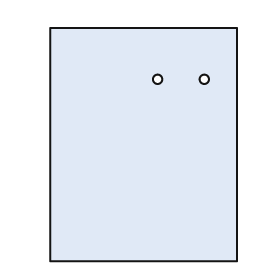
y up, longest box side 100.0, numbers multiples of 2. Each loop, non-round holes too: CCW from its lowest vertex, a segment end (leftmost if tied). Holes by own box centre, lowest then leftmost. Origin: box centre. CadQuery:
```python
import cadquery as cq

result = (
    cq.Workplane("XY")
    .moveTo(-40.0, -50.0)
    .lineTo(40.0, -50.0)
    .lineTo(40.0, 50.0)
    .lineTo(-40.0, 50.0)
    .close()
    .moveTo(6.0, 28.0)
    .circle(2.0)
    .moveTo(26.0, 28.0)
    .circle(2.0)
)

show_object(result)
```